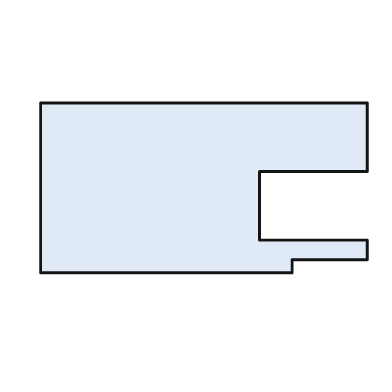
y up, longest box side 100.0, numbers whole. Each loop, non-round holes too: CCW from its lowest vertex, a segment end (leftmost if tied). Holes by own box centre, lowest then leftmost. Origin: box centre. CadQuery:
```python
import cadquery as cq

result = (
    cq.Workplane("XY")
    .moveTo(-50.0, -26.0)
    .lineTo(27.0, -26.0)
    .lineTo(27.0, -22.0)
    .lineTo(50.0, -22.0)
    .lineTo(50.0, -16.0)
    .lineTo(17.0, -16.0)
    .lineTo(17.0, 5.0)
    .lineTo(50.0, 5.0)
    .lineTo(50.0, 26.0)
    .lineTo(-50.0, 26.0)
    .close()
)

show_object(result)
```